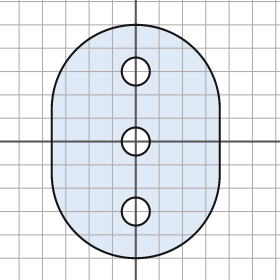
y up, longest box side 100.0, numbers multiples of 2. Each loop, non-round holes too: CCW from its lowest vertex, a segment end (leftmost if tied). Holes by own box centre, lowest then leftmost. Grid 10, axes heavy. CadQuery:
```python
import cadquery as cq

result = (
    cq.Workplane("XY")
    .moveTo(-36.0, -14.0)
    .threePointArc((0.0, -50.0), (36.0, -14.0))
    .lineTo(36.0, 14.0)
    .threePointArc((0.0, 50.0), (-36.0, 14.0))
    .close()
    .moveTo(0.0, -30.0)
    .circle(6.0)
    .moveTo(0.0, 0.0)
    .circle(6.0)
    .moveTo(0.0, 30.0)
    .circle(6.0)
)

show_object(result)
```